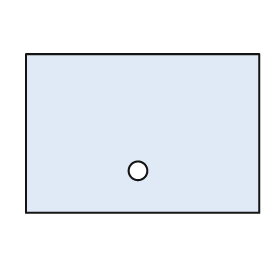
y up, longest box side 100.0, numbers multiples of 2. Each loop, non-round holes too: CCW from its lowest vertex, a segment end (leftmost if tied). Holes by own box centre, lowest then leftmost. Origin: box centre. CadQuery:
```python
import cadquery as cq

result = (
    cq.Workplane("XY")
    .moveTo(-50.0, -34.0)
    .lineTo(50.0, -34.0)
    .lineTo(50.0, 34.0)
    .lineTo(-50.0, 34.0)
    .close()
    .moveTo(-2.0, -16.0)
    .circle(4.0)
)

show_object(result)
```